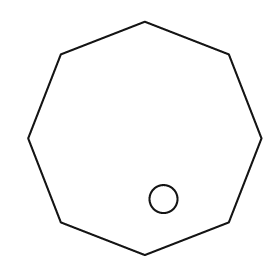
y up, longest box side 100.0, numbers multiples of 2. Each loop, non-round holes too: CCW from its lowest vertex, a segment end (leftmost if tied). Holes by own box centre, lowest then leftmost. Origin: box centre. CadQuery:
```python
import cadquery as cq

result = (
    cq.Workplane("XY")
    .moveTo(0.0, -50.0)
    .lineTo(36.0, -36.0)
    .lineTo(50.0, 0.0)
    .lineTo(36.0, 36.0)
    .lineTo(0.0, 50.0)
    .lineTo(-36.0, 36.0)
    .lineTo(-50.0, 0.0)
    .lineTo(-36.0, -36.0)
    .close()
    .moveTo(8.0, -26.0)
    .circle(6.0)
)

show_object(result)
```